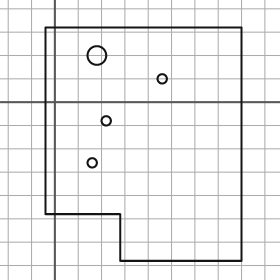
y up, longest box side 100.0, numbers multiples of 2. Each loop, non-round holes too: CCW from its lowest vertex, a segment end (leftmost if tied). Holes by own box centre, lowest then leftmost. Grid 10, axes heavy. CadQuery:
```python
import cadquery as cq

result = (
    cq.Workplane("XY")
    .moveTo(28.0, -68.0)
    .lineTo(80.0, -68.0)
    .lineTo(80.0, 32.0)
    .lineTo(-4.0, 32.0)
    .lineTo(-4.0, -48.0)
    .lineTo(28.0, -48.0)
    .close()
    .moveTo(16.0, -26.0)
    .circle(2.0)
    .moveTo(22.0, -8.0)
    .circle(2.0)
    .moveTo(46.0, 10.0)
    .circle(2.0)
    .moveTo(18.0, 20.0)
    .circle(4.0)
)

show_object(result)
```